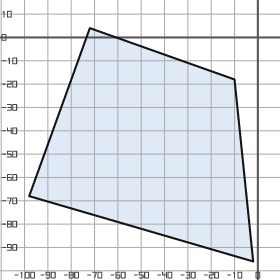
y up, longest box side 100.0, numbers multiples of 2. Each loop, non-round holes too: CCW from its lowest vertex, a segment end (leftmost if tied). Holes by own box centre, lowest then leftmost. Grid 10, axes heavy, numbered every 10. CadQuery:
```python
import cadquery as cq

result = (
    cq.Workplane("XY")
    .moveTo(-2.0, -96.0)
    .lineTo(-10.0, -18.0)
    .lineTo(-72.0, 4.0)
    .lineTo(-98.0, -68.0)
    .close()
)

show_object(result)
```